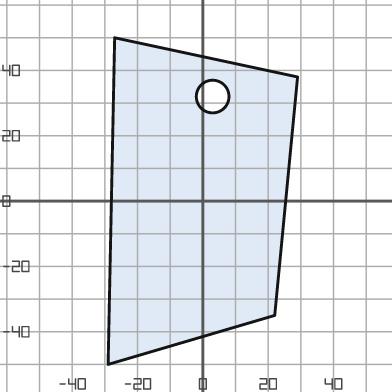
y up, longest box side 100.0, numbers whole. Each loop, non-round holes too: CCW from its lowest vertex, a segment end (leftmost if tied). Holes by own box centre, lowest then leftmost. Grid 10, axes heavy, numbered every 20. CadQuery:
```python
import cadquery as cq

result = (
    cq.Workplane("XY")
    .moveTo(-29.0, -50.0)
    .lineTo(22.0, -35.0)
    .lineTo(29.0, 38.0)
    .lineTo(-27.0, 50.0)
    .close()
    .moveTo(3.0, 32.0)
    .circle(5.0)
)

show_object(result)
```